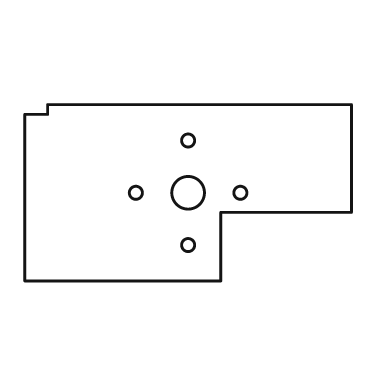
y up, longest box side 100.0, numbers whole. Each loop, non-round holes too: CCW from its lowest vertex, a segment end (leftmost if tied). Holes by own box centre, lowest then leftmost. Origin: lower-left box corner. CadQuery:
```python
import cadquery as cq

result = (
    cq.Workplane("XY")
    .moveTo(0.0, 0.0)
    .lineTo(60.0, 0.0)
    .lineTo(60.0, 21.0)
    .lineTo(100.0, 21.0)
    .lineTo(100.0, 54.0)
    .lineTo(7.0, 54.0)
    .lineTo(7.0, 51.0)
    .lineTo(0.0, 51.0)
    .close()
    .moveTo(50.0, 11.0)
    .circle(2.0)
    .moveTo(34.0, 27.0)
    .circle(2.0)
    .moveTo(50.0, 27.0)
    .circle(5.0)
    .moveTo(66.0, 27.0)
    .circle(2.0)
    .moveTo(50.0, 43.0)
    .circle(2.0)
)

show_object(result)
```